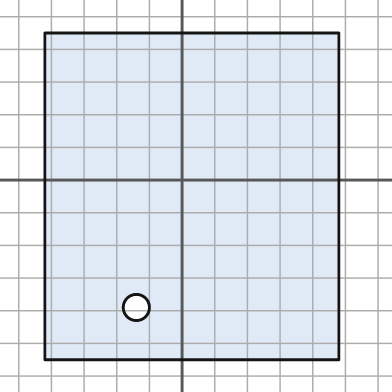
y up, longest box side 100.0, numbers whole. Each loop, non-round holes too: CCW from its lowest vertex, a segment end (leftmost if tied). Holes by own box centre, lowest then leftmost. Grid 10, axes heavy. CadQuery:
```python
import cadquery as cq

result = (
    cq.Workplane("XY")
    .moveTo(-42.0, -55.0)
    .lineTo(48.0, -55.0)
    .lineTo(48.0, 45.0)
    .lineTo(-42.0, 45.0)
    .close()
    .moveTo(-14.0, -39.0)
    .circle(4.0)
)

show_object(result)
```